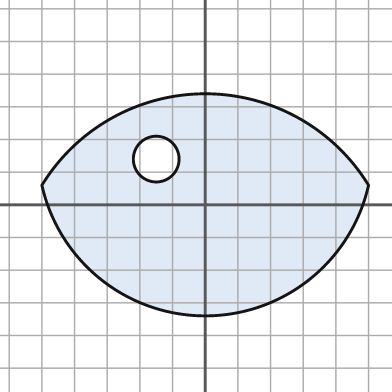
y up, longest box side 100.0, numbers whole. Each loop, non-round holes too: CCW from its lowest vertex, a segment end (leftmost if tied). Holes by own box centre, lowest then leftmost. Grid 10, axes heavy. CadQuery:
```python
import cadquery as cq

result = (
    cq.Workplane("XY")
    .moveTo(-50.0, 6.0)
    .threePointArc((0.0, -34.0), (50.0, 6.0))
    .threePointArc((0.0, 34.0), (-50.0, 6.0))
    .close()
    .moveTo(-15.0, 14.0)
    .circle(7.0)
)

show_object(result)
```